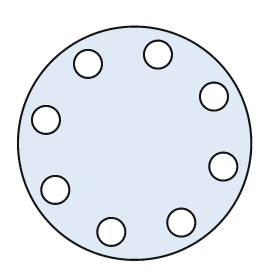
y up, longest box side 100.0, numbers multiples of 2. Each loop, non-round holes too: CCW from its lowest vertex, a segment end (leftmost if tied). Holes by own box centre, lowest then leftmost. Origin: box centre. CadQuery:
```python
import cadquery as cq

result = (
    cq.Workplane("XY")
    .moveTo(0.0, 0.0)
    .circle(50.0)
    .moveTo(-10.0, -38.0)
    .circle(6.0)
    .moveTo(20.0, -34.0)
    .circle(6.0)
    .moveTo(-34.0, -20.0)
    .circle(6.0)
    .moveTo(38.0, -10.0)
    .circle(6.0)
    .moveTo(-38.0, 10.0)
    .circle(6.0)
    .moveTo(34.0, 20.0)
    .circle(6.0)
    .moveTo(-20.0, 34.0)
    .circle(6.0)
    .moveTo(10.0, 38.0)
    .circle(6.0)
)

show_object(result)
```